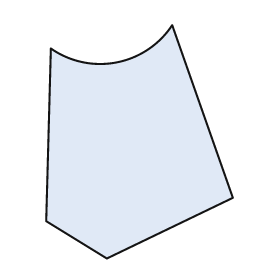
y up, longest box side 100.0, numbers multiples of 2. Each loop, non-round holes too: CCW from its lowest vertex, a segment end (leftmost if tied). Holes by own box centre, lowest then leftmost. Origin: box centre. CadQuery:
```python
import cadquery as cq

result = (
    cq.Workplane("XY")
    .moveTo(-14.0, -50.0)
    .lineTo(40.0, -24.0)
    .lineTo(14.0, 50.0)
    .threePointArc((-10.0, 34.0), (-38.0, 40.0))
    .lineTo(-40.0, -34.0)
    .close()
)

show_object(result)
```